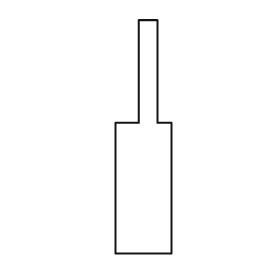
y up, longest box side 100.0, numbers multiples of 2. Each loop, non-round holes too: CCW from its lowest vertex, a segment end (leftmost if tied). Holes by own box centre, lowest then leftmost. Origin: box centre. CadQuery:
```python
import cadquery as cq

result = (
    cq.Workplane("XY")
    .moveTo(-12.0, -50.0)
    .lineTo(12.0, -50.0)
    .lineTo(12.0, 6.0)
    .lineTo(6.0, 6.0)
    .lineTo(6.0, 50.0)
    .lineTo(-2.0, 50.0)
    .lineTo(-2.0, 6.0)
    .lineTo(-12.0, 6.0)
    .close()
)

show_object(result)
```